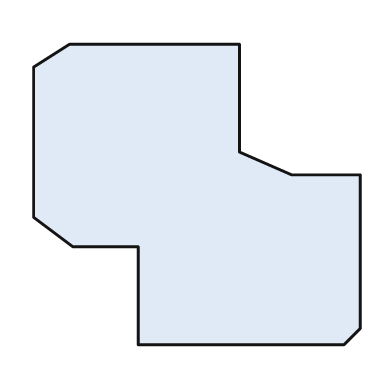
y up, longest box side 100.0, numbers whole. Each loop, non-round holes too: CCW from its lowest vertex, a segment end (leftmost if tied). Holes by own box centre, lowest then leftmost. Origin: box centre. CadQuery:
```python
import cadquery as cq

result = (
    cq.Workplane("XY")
    .moveTo(-18.0, -46.0)
    .lineTo(45.0, -46.0)
    .lineTo(50.0, -41.0)
    .lineTo(50.0, 6.0)
    .lineTo(29.0, 6.0)
    .lineTo(13.0, 13.0)
    .lineTo(13.0, 46.0)
    .lineTo(-39.0, 46.0)
    .lineTo(-50.0, 39.0)
    .lineTo(-50.0, -7.0)
    .lineTo(-38.0, -16.0)
    .lineTo(-18.0, -16.0)
    .close()
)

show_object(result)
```